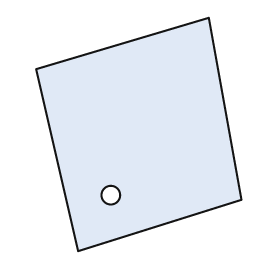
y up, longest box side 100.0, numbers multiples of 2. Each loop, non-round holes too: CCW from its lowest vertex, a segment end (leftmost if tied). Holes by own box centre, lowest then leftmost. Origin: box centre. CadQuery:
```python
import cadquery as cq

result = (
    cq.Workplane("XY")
    .moveTo(-26.0, -50.0)
    .lineTo(44.0, -28.0)
    .lineTo(30.0, 50.0)
    .lineTo(-44.0, 28.0)
    .close()
    .moveTo(-12.0, -26.0)
    .circle(4.0)
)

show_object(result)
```